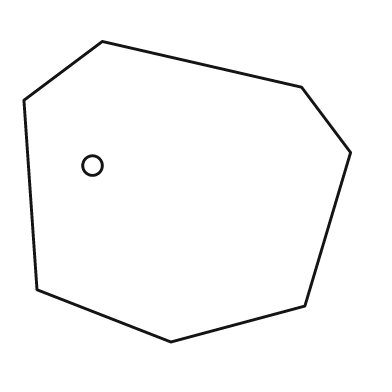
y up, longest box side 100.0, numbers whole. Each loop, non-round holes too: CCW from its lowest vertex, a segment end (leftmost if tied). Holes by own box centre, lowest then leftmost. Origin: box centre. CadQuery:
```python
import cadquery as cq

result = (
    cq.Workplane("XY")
    .moveTo(-5.0, -46.0)
    .lineTo(36.0, -35.0)
    .lineTo(50.0, 12.0)
    .lineTo(35.0, 32.0)
    .lineTo(-26.0, 46.0)
    .lineTo(-50.0, 28.0)
    .lineTo(-46.0, -30.0)
    .close()
    .moveTo(-29.0, 8.0)
    .circle(3.0)
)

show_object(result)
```